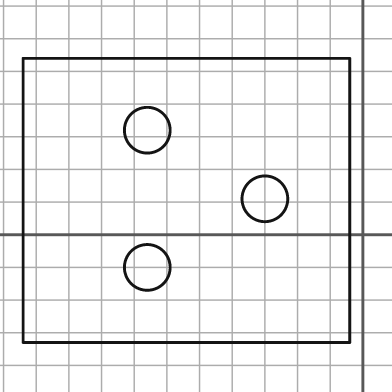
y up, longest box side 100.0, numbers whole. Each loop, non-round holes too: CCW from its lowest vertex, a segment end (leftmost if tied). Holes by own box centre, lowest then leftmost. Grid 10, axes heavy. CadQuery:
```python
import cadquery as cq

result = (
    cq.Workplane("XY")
    .moveTo(-104.0, -33.0)
    .lineTo(-4.0, -33.0)
    .lineTo(-4.0, 54.0)
    .lineTo(-104.0, 54.0)
    .close()
    .moveTo(-66.0, -10.0)
    .circle(7.0)
    .moveTo(-30.0, 11.0)
    .circle(7.0)
    .moveTo(-66.0, 32.0)
    .circle(7.0)
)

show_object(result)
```